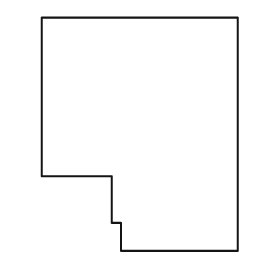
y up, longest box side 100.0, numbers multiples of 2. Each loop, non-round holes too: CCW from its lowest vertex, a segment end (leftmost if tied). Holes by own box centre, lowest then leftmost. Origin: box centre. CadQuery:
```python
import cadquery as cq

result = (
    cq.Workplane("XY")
    .moveTo(-8.0, -50.0)
    .lineTo(42.0, -50.0)
    .lineTo(42.0, 50.0)
    .lineTo(-42.0, 50.0)
    .lineTo(-42.0, -18.0)
    .lineTo(-12.0, -18.0)
    .lineTo(-12.0, -38.0)
    .lineTo(-8.0, -38.0)
    .close()
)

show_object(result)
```